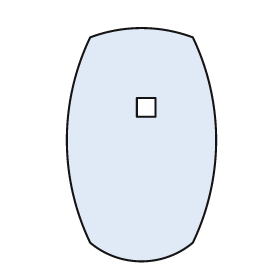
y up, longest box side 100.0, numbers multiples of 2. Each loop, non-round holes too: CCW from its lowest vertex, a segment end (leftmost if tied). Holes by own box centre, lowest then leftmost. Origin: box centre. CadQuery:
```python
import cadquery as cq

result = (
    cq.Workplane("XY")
    .moveTo(-22.0, -42.0)
    .threePointArc((0.0, -50.0), (22.0, -42.0))
    .threePointArc((32.0, 2.0), (22.0, 46.0))
    .threePointArc((0.0, 50.0), (-22.0, 46.0))
    .threePointArc((-32.0, 2.0), (-22.0, -42.0))
    .close()
    .moveTo(-2.0, 12.0)
    .lineTo(6.0, 12.0)
    .lineTo(6.0, 20.0)
    .lineTo(-2.0, 20.0)
    .close()
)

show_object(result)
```